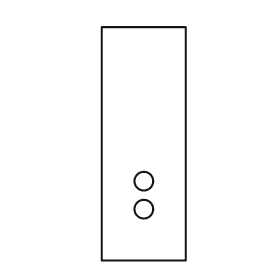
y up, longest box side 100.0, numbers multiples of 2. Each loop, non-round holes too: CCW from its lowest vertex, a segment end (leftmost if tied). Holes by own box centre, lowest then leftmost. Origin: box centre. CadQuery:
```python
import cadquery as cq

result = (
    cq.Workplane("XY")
    .moveTo(-18.0, -50.0)
    .lineTo(18.0, -50.0)
    .lineTo(18.0, 50.0)
    .lineTo(-18.0, 50.0)
    .close()
    .moveTo(0.0, -28.0)
    .circle(4.0)
    .moveTo(0.0, -16.0)
    .circle(4.0)
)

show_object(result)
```